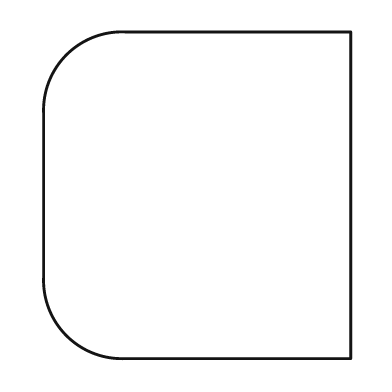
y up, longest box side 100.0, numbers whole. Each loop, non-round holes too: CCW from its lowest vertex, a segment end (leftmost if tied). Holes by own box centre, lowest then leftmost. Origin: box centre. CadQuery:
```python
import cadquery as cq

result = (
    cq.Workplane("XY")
    .moveTo(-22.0, -50.0)
    .lineTo(47.0, -50.0)
    .lineTo(47.0, 50.0)
    .lineTo(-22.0, 50.0)
    .threePointArc((-40.0, 43.0), (-47.0, 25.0))
    .lineTo(-47.0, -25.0)
    .threePointArc((-40.0, -43.0), (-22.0, -50.0))
    .close()
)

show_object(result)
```